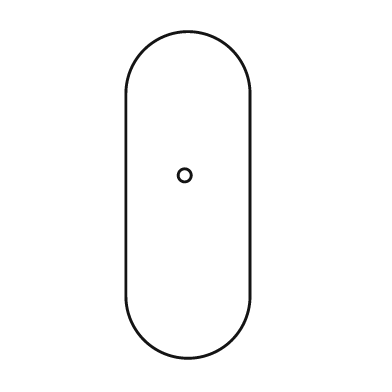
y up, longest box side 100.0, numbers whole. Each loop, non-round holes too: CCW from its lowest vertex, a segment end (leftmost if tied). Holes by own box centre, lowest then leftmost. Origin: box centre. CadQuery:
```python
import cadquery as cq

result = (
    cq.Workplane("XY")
    .moveTo(-19.0, -31.0)
    .threePointArc((0.0, -50.0), (19.0, -31.0))
    .lineTo(19.0, 31.0)
    .threePointArc((0.0, 50.0), (-19.0, 31.0))
    .close()
    .moveTo(-1.0, 6.0)
    .circle(2.0)
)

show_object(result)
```